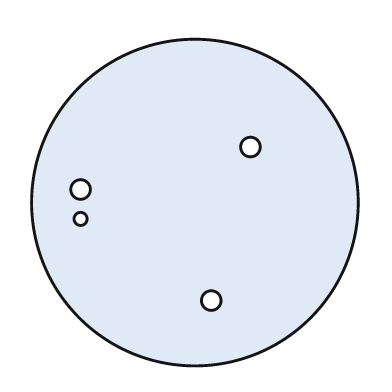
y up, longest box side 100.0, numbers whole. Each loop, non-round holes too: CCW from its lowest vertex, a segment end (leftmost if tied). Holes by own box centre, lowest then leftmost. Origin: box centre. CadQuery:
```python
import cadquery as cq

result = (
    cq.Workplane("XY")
    .moveTo(0.0, 0.0)
    .circle(50.0)
    .moveTo(5.0, -30.0)
    .circle(3.0)
    .moveTo(-35.0, -5.0)
    .circle(2.0)
    .moveTo(-35.0, 4.0)
    .circle(3.0)
    .moveTo(17.0, 17.0)
    .circle(3.0)
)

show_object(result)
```